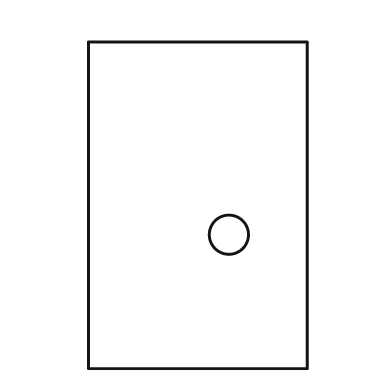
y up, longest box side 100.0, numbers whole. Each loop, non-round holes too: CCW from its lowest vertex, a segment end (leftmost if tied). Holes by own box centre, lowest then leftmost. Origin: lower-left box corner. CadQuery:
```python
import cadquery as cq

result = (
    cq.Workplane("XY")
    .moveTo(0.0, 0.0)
    .lineTo(67.0, 0.0)
    .lineTo(67.0, 100.0)
    .lineTo(0.0, 100.0)
    .close()
    .moveTo(43.0, 41.0)
    .circle(6.0)
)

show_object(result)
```